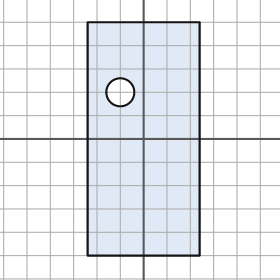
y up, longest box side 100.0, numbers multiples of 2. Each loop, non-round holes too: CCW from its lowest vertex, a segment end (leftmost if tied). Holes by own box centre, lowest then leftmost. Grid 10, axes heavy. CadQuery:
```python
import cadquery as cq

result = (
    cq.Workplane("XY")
    .moveTo(-24.0, -50.0)
    .lineTo(24.0, -50.0)
    .lineTo(24.0, 50.0)
    .lineTo(-24.0, 50.0)
    .close()
    .moveTo(-10.0, 20.0)
    .circle(6.0)
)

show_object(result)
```